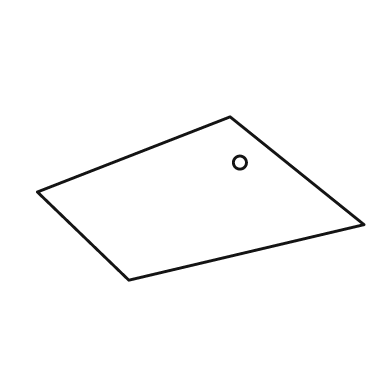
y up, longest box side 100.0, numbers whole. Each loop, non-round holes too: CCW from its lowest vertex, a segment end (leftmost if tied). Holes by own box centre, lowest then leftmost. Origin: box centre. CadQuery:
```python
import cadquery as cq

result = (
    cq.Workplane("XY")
    .moveTo(-22.0, -25.0)
    .lineTo(50.0, -8.0)
    .lineTo(9.0, 25.0)
    .lineTo(-50.0, 2.0)
    .close()
    .moveTo(12.0, 11.0)
    .circle(2.0)
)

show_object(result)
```